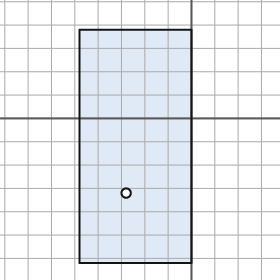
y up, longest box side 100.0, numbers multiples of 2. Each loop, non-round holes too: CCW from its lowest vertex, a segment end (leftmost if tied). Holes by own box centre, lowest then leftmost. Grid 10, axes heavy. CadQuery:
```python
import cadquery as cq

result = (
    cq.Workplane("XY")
    .moveTo(-48.0, -62.0)
    .lineTo(0.0, -62.0)
    .lineTo(0.0, 38.0)
    .lineTo(-48.0, 38.0)
    .close()
    .moveTo(-28.0, -32.0)
    .circle(2.0)
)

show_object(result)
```